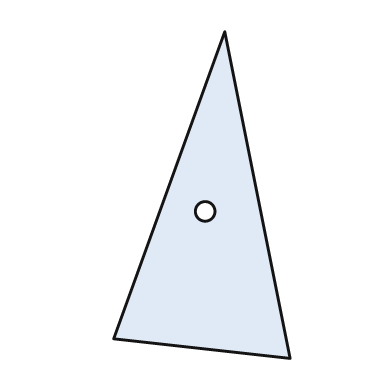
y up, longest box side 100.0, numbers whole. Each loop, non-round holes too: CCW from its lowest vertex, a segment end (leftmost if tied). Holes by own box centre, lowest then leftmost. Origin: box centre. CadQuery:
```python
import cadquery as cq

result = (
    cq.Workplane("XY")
    .moveTo(27.0, -50.0)
    .lineTo(7.0, 50.0)
    .lineTo(-27.0, -44.0)
    .close()
    .moveTo(1.0, -5.0)
    .circle(3.0)
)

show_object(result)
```